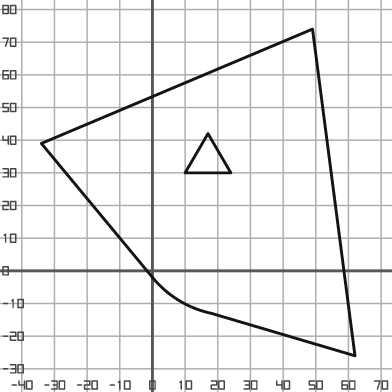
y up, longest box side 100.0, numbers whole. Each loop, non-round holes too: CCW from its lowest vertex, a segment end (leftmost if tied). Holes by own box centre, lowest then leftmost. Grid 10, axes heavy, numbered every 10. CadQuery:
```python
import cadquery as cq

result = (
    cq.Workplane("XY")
    .moveTo(62.0, -26.0)
    .lineTo(49.0, 74.0)
    .lineTo(-34.0, 39.0)
    .lineTo(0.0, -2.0)
    .threePointArc((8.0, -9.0), (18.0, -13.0))
    .close()
    .moveTo(10.0, 30.0)
    .lineTo(24.0, 30.0)
    .lineTo(17.0, 42.0)
    .close()
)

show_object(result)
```